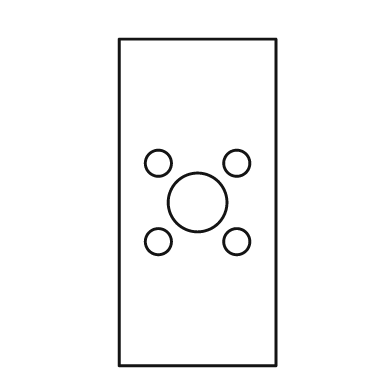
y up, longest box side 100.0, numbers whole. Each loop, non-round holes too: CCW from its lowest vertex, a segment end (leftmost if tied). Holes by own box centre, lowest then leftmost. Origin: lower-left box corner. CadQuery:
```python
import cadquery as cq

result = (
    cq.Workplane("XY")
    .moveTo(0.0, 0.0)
    .lineTo(48.0, 0.0)
    .lineTo(48.0, 100.0)
    .lineTo(0.0, 100.0)
    .close()
    .moveTo(12.0, 38.0)
    .circle(4.0)
    .moveTo(36.0, 38.0)
    .circle(4.0)
    .moveTo(24.0, 50.0)
    .circle(9.0)
    .moveTo(12.0, 62.0)
    .circle(4.0)
    .moveTo(36.0, 62.0)
    .circle(4.0)
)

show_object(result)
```